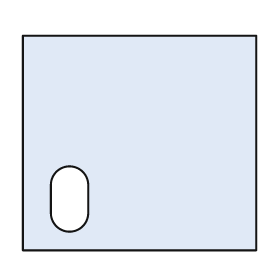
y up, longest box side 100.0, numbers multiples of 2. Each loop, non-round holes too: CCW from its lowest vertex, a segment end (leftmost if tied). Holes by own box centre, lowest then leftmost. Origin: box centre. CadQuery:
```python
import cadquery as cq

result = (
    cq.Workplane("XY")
    .moveTo(-50.0, -46.0)
    .lineTo(50.0, -46.0)
    .lineTo(50.0, 46.0)
    .lineTo(-50.0, 46.0)
    .close()
    .moveTo(-38.0, -30.0)
    .threePointArc((-30.0, -38.0), (-22.0, -30.0))
    .lineTo(-22.0, -18.0)
    .threePointArc((-30.0, -10.0), (-38.0, -18.0))
    .close()
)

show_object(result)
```